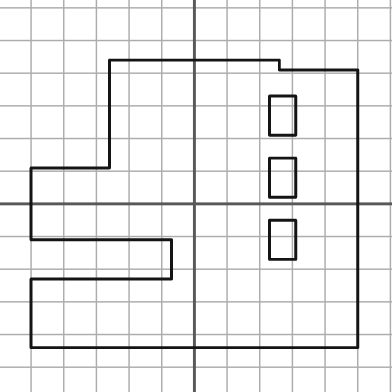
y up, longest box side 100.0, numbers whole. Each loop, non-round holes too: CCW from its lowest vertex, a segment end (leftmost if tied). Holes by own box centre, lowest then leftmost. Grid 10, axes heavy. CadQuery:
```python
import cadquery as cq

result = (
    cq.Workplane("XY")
    .moveTo(-50.0, -44.0)
    .lineTo(50.0, -44.0)
    .lineTo(50.0, 41.0)
    .lineTo(26.0, 41.0)
    .lineTo(26.0, 44.0)
    .lineTo(-26.0, 44.0)
    .lineTo(-26.0, 11.0)
    .lineTo(-50.0, 11.0)
    .lineTo(-50.0, -11.0)
    .lineTo(-7.0, -11.0)
    .lineTo(-7.0, -23.0)
    .lineTo(-50.0, -23.0)
    .close()
    .moveTo(23.0, -17.0)
    .lineTo(31.0, -17.0)
    .lineTo(31.0, -5.0)
    .lineTo(23.0, -5.0)
    .close()
    .moveTo(23.0, 2.0)
    .lineTo(31.0, 2.0)
    .lineTo(31.0, 14.0)
    .lineTo(23.0, 14.0)
    .close()
    .moveTo(23.0, 21.0)
    .lineTo(31.0, 21.0)
    .lineTo(31.0, 33.0)
    .lineTo(23.0, 33.0)
    .close()
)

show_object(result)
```